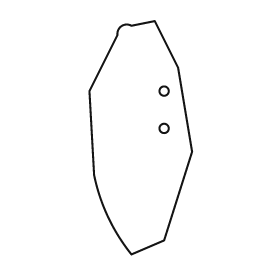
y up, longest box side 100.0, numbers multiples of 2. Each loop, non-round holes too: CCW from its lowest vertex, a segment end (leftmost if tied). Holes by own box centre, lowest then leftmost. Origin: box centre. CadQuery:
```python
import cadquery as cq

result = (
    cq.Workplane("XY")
    .moveTo(-4.0, -50.0)
    .lineTo(10.0, -44.0)
    .lineTo(22.0, -6.0)
    .lineTo(16.0, 30.0)
    .lineTo(6.0, 50.0)
    .lineTo(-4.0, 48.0)
    .threePointArc((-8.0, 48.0), (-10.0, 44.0))
    .lineTo(-22.0, 20.0)
    .lineTo(-20.0, -16.0)
    .threePointArc((-14.0, -34.0), (-4.0, -50.0))
    .close()
    .moveTo(10.0, 4.0)
    .circle(2.0)
    .moveTo(10.0, 20.0)
    .circle(2.0)
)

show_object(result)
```